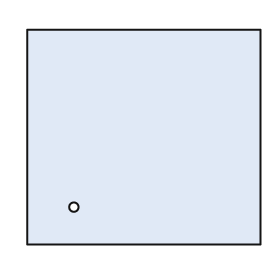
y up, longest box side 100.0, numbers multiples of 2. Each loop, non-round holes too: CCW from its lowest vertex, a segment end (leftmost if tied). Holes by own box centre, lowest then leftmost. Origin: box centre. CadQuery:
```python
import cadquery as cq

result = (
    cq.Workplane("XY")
    .moveTo(-50.0, -46.0)
    .lineTo(50.0, -46.0)
    .lineTo(50.0, 46.0)
    .lineTo(-50.0, 46.0)
    .close()
    .moveTo(-30.0, -30.0)
    .circle(2.0)
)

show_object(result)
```